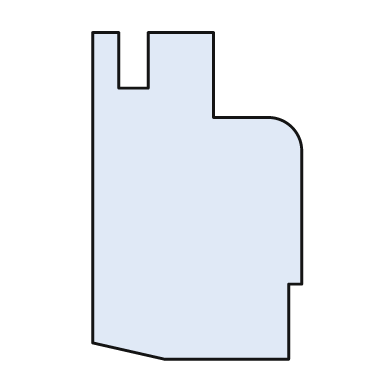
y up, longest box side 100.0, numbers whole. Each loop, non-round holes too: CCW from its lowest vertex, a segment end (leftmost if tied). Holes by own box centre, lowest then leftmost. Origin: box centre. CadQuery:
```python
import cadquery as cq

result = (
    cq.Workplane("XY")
    .moveTo(-10.0, -50.0)
    .lineTo(28.0, -50.0)
    .lineTo(28.0, -27.0)
    .lineTo(32.0, -27.0)
    .lineTo(32.0, 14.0)
    .threePointArc((29.0, 21.0), (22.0, 24.0))
    .lineTo(5.0, 24.0)
    .lineTo(5.0, 50.0)
    .lineTo(-15.0, 50.0)
    .lineTo(-15.0, 33.0)
    .lineTo(-24.0, 33.0)
    .lineTo(-24.0, 50.0)
    .lineTo(-32.0, 50.0)
    .lineTo(-32.0, -45.0)
    .close()
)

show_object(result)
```